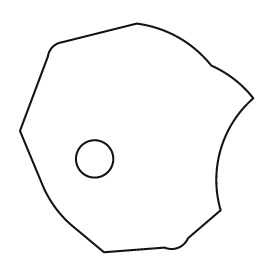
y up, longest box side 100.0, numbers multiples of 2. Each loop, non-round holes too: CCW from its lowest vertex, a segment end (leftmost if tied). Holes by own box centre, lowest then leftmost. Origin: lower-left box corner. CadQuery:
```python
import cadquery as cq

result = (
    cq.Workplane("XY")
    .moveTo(36.0, 0.0)
    .lineTo(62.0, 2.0)
    .threePointArc((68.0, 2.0), (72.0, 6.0))
    .lineTo(86.0, 18.0)
    .threePointArc((86.0, 44.0), (100.0, 66.0))
    .threePointArc((92.0, 74.0), (82.0, 80.0))
    .threePointArc((68.0, 92.0), (50.0, 98.0))
    .lineTo(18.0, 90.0)
    .threePointArc((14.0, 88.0), (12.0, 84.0))
    .lineTo(0.0, 52.0)
    .lineTo(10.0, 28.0)
    .threePointArc((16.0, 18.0), (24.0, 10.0))
    .close()
    .moveTo(32.0, 40.0)
    .circle(8.0)
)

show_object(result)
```